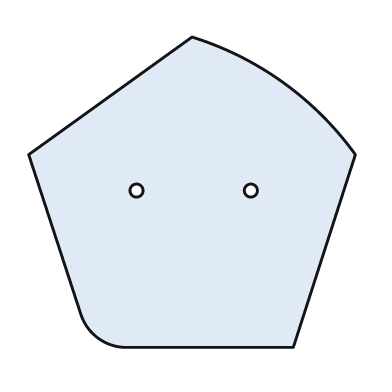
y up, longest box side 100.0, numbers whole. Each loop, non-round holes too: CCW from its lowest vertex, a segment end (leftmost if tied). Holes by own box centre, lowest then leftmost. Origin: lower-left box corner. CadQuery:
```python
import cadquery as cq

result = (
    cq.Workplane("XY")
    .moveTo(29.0, 0.0)
    .lineTo(81.0, 0.0)
    .lineTo(100.0, 59.0)
    .threePointArc((78.0, 81.0), (50.0, 95.0))
    .lineTo(0.0, 59.0)
    .lineTo(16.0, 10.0)
    .threePointArc((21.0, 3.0), (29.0, 0.0))
    .close()
    .moveTo(33.0, 48.0)
    .circle(2.0)
    .moveTo(68.0, 48.0)
    .circle(2.0)
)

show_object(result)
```